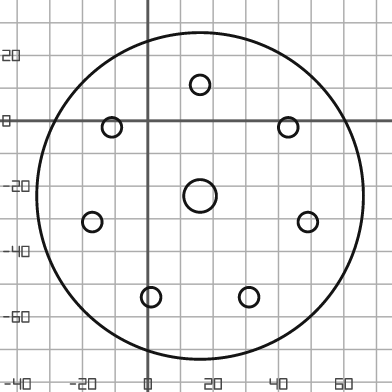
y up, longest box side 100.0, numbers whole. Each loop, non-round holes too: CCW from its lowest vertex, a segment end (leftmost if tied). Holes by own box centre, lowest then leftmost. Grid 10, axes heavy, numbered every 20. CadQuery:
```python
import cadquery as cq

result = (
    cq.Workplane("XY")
    .moveTo(16.0, -23.0)
    .circle(50.0)
    .moveTo(1.0, -54.0)
    .circle(3.0)
    .moveTo(31.0, -54.0)
    .circle(3.0)
    .moveTo(-17.0, -31.0)
    .circle(3.0)
    .moveTo(49.0, -31.0)
    .circle(3.0)
    .moveTo(16.0, -23.0)
    .circle(5.0)
    .moveTo(-11.0, -2.0)
    .circle(3.0)
    .moveTo(43.0, -2.0)
    .circle(3.0)
    .moveTo(16.0, 11.0)
    .circle(3.0)
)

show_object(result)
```